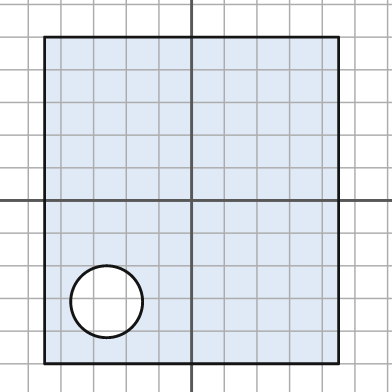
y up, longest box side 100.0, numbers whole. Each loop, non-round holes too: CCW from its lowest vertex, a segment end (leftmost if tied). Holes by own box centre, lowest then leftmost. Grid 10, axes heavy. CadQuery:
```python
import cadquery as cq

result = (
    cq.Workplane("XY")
    .moveTo(-45.0, -50.0)
    .lineTo(45.0, -50.0)
    .lineTo(45.0, 50.0)
    .lineTo(-45.0, 50.0)
    .close()
    .moveTo(-26.0, -31.0)
    .circle(11.0)
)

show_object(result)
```